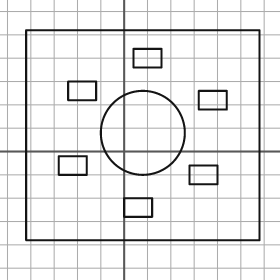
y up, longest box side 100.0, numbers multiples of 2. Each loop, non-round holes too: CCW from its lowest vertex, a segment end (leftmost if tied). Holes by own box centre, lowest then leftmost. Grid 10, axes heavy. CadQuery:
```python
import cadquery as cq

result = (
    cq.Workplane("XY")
    .moveTo(-42.0, -38.0)
    .lineTo(58.0, -38.0)
    .lineTo(58.0, 52.0)
    .lineTo(-42.0, 52.0)
    .close()
    .moveTo(0.0, -28.0)
    .lineTo(12.0, -28.0)
    .lineTo(12.0, -20.0)
    .lineTo(0.0, -20.0)
    .close()
    .moveTo(28.0, -14.0)
    .lineTo(40.0, -14.0)
    .lineTo(40.0, -6.0)
    .lineTo(28.0, -6.0)
    .close()
    .moveTo(-28.0, -10.0)
    .lineTo(-16.0, -10.0)
    .lineTo(-16.0, -2.0)
    .lineTo(-28.0, -2.0)
    .close()
    .moveTo(8.0, 8.0)
    .circle(18.0)
    .moveTo(32.0, 18.0)
    .lineTo(44.0, 18.0)
    .lineTo(44.0, 26.0)
    .lineTo(32.0, 26.0)
    .close()
    .moveTo(-24.0, 22.0)
    .lineTo(-12.0, 22.0)
    .lineTo(-12.0, 30.0)
    .lineTo(-24.0, 30.0)
    .close()
    .moveTo(4.0, 36.0)
    .lineTo(16.0, 36.0)
    .lineTo(16.0, 44.0)
    .lineTo(4.0, 44.0)
    .close()
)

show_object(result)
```